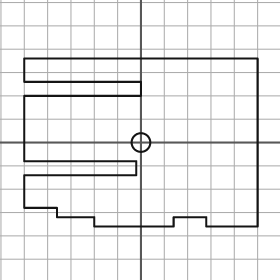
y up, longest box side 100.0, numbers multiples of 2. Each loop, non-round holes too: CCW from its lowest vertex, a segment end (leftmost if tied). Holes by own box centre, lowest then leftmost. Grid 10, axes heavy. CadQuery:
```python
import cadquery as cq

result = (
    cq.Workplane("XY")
    .moveTo(-20.0, -36.0)
    .lineTo(14.0, -36.0)
    .lineTo(14.0, -32.0)
    .lineTo(28.0, -32.0)
    .lineTo(28.0, -36.0)
    .lineTo(50.0, -36.0)
    .lineTo(50.0, 36.0)
    .lineTo(-50.0, 36.0)
    .lineTo(-50.0, 26.0)
    .lineTo(0.0, 26.0)
    .lineTo(0.0, 20.0)
    .lineTo(-50.0, 20.0)
    .lineTo(-50.0, -8.0)
    .lineTo(-2.0, -8.0)
    .lineTo(-2.0, -14.0)
    .lineTo(-50.0, -14.0)
    .lineTo(-50.0, -28.0)
    .lineTo(-36.0, -28.0)
    .lineTo(-36.0, -32.0)
    .lineTo(-20.0, -32.0)
    .close()
    .moveTo(0.0, 0.0)
    .circle(4.0)
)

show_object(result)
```